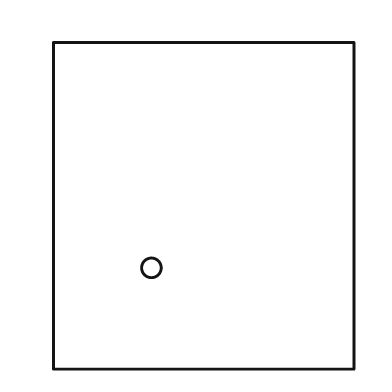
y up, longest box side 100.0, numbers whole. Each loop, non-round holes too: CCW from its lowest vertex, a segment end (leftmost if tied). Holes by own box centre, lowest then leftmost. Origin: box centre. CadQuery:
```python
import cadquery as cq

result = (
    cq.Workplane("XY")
    .moveTo(-46.0, -50.0)
    .lineTo(46.0, -50.0)
    .lineTo(46.0, 50.0)
    .lineTo(-46.0, 50.0)
    .close()
    .moveTo(-16.0, -19.0)
    .circle(3.0)
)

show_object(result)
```